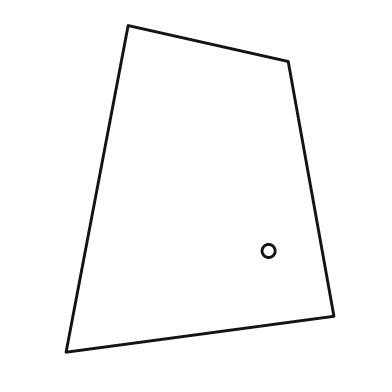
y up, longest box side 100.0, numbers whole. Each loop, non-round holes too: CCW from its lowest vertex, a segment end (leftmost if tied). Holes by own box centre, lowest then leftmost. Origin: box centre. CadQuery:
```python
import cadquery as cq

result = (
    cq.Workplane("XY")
    .moveTo(-41.0, -50.0)
    .lineTo(41.0, -39.0)
    .lineTo(27.0, 39.0)
    .lineTo(-22.0, 50.0)
    .close()
    .moveTo(21.0, -19.0)
    .circle(2.0)
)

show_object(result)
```